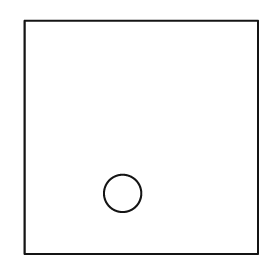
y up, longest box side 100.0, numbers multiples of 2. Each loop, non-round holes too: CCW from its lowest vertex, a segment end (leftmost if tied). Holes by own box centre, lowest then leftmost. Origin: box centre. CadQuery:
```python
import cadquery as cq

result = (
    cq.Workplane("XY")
    .moveTo(-50.0, -50.0)
    .lineTo(50.0, -50.0)
    .lineTo(50.0, 50.0)
    .lineTo(-50.0, 50.0)
    .close()
    .moveTo(-8.0, -24.0)
    .circle(8.0)
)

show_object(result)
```